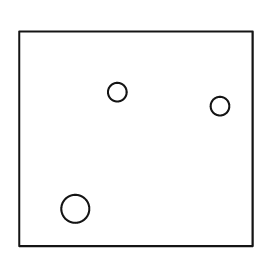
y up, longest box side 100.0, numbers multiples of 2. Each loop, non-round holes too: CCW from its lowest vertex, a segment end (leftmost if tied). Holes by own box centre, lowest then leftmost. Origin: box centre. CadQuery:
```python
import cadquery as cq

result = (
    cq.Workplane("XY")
    .moveTo(-50.0, -46.0)
    .lineTo(50.0, -46.0)
    .lineTo(50.0, 46.0)
    .lineTo(-50.0, 46.0)
    .close()
    .moveTo(-26.0, -30.0)
    .circle(6.0)
    .moveTo(36.0, 14.0)
    .circle(4.0)
    .moveTo(-8.0, 20.0)
    .circle(4.0)
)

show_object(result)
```